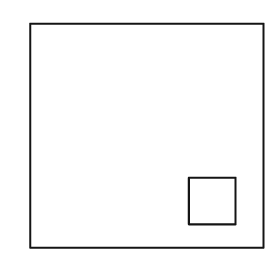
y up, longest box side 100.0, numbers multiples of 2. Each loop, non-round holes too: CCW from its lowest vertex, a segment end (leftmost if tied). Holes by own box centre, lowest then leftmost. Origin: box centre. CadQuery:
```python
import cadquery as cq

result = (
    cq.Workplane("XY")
    .moveTo(-50.0, -48.0)
    .lineTo(50.0, -48.0)
    .lineTo(50.0, 48.0)
    .lineTo(-50.0, 48.0)
    .close()
    .moveTo(18.0, -38.0)
    .lineTo(38.0, -38.0)
    .lineTo(38.0, -18.0)
    .lineTo(18.0, -18.0)
    .close()
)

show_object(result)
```